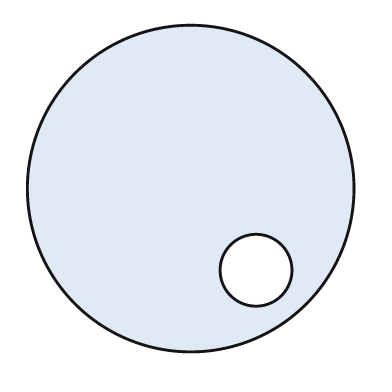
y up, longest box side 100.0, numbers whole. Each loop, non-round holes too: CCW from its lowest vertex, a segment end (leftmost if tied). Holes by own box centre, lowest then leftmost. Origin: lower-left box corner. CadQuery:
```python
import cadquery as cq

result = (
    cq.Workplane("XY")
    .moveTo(50.0, 50.0)
    .circle(50.0)
    .moveTo(70.0, 25.0)
    .circle(11.0)
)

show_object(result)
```